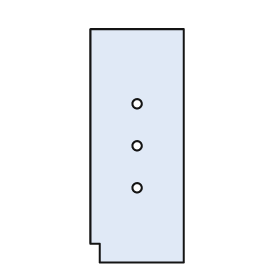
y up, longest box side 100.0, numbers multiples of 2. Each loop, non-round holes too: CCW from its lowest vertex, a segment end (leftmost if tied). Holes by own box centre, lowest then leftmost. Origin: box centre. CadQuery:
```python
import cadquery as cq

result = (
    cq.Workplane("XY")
    .moveTo(-16.0, -50.0)
    .lineTo(20.0, -50.0)
    .lineTo(20.0, 50.0)
    .lineTo(-20.0, 50.0)
    .lineTo(-20.0, -42.0)
    .lineTo(-16.0, -42.0)
    .close()
    .moveTo(0.0, -18.0)
    .circle(2.0)
    .moveTo(0.0, 0.0)
    .circle(2.0)
    .moveTo(0.0, 18.0)
    .circle(2.0)
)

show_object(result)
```